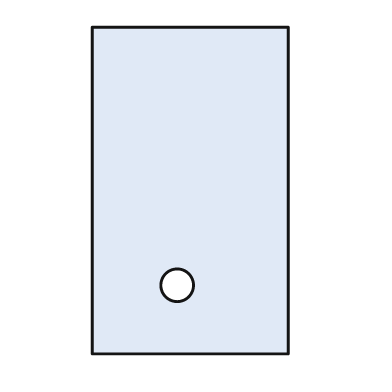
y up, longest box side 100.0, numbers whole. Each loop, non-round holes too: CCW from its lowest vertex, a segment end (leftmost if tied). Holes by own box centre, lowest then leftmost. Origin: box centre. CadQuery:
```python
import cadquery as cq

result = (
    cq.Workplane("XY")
    .moveTo(-30.0, -50.0)
    .lineTo(30.0, -50.0)
    .lineTo(30.0, 50.0)
    .lineTo(-30.0, 50.0)
    .close()
    .moveTo(-4.0, -29.0)
    .circle(5.0)
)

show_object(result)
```